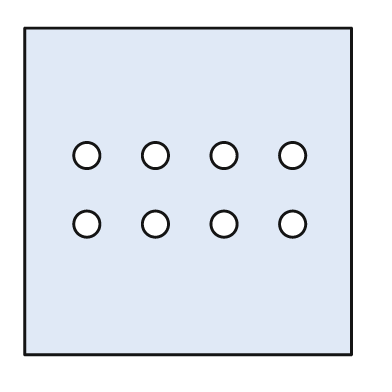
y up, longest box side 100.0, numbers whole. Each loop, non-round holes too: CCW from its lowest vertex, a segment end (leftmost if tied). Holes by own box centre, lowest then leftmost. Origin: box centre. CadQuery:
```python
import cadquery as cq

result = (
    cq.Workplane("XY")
    .moveTo(-50.0, -50.0)
    .lineTo(50.0, -50.0)
    .lineTo(50.0, 50.0)
    .lineTo(-50.0, 50.0)
    .close()
    .moveTo(-31.0, -10.0)
    .circle(4.0)
    .moveTo(-10.0, -10.0)
    .circle(4.0)
    .moveTo(11.0, -10.0)
    .circle(4.0)
    .moveTo(32.0, -10.0)
    .circle(4.0)
    .moveTo(-31.0, 11.0)
    .circle(4.0)
    .moveTo(-10.0, 11.0)
    .circle(4.0)
    .moveTo(11.0, 11.0)
    .circle(4.0)
    .moveTo(32.0, 11.0)
    .circle(4.0)
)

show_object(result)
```